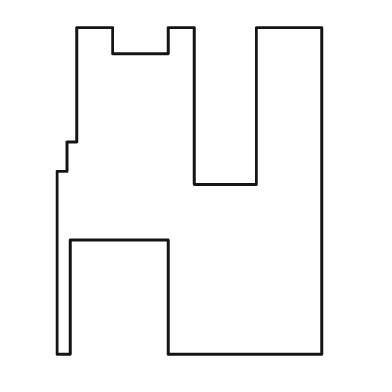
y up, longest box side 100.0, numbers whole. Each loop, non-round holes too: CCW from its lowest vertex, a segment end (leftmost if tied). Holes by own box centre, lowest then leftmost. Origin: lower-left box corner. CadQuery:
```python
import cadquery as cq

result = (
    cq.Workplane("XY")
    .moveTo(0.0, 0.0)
    .lineTo(4.0, 0.0)
    .lineTo(4.0, 35.0)
    .lineTo(34.0, 35.0)
    .lineTo(34.0, 0.0)
    .lineTo(81.0, 0.0)
    .lineTo(81.0, 100.0)
    .lineTo(61.0, 100.0)
    .lineTo(61.0, 52.0)
    .lineTo(42.0, 52.0)
    .lineTo(42.0, 100.0)
    .lineTo(34.0, 100.0)
    .lineTo(34.0, 92.0)
    .lineTo(17.0, 92.0)
    .lineTo(17.0, 100.0)
    .lineTo(6.0, 100.0)
    .lineTo(6.0, 65.0)
    .lineTo(3.0, 65.0)
    .lineTo(3.0, 56.0)
    .lineTo(0.0, 56.0)
    .close()
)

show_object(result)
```